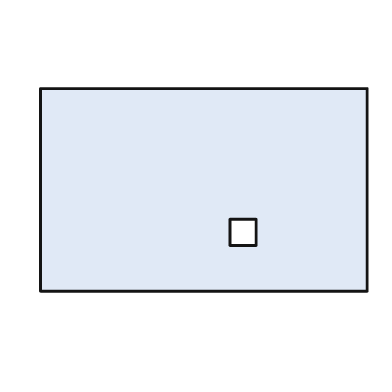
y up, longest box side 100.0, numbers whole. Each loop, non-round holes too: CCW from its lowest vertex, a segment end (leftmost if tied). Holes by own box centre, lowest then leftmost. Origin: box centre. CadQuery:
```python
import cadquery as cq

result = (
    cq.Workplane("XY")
    .moveTo(-50.0, -31.0)
    .lineTo(50.0, -31.0)
    .lineTo(50.0, 31.0)
    .lineTo(-50.0, 31.0)
    .close()
    .moveTo(8.0, -17.0)
    .lineTo(16.0, -17.0)
    .lineTo(16.0, -9.0)
    .lineTo(8.0, -9.0)
    .close()
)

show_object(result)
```